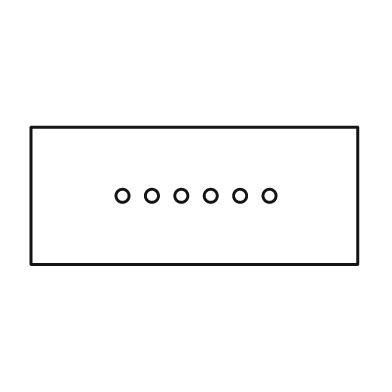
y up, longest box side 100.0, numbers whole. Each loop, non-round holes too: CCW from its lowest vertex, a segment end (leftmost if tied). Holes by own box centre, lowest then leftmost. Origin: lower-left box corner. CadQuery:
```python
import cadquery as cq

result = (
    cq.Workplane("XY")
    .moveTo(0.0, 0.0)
    .lineTo(100.0, 0.0)
    .lineTo(100.0, 42.0)
    .lineTo(0.0, 42.0)
    .close()
    .moveTo(28.0, 21.0)
    .circle(2.0)
    .moveTo(37.0, 21.0)
    .circle(2.0)
    .moveTo(46.0, 21.0)
    .circle(2.0)
    .moveTo(55.0, 21.0)
    .circle(2.0)
    .moveTo(64.0, 21.0)
    .circle(2.0)
    .moveTo(73.0, 21.0)
    .circle(2.0)
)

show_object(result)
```